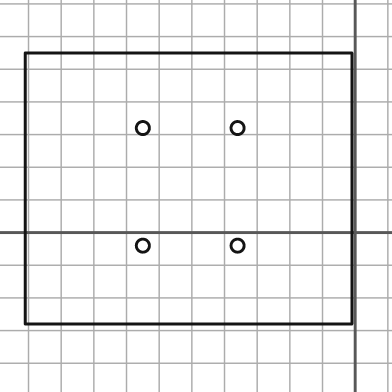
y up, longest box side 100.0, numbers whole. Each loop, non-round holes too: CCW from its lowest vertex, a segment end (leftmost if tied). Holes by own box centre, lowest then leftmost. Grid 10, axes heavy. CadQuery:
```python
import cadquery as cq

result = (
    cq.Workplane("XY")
    .moveTo(-101.0, -28.0)
    .lineTo(-1.0, -28.0)
    .lineTo(-1.0, 55.0)
    .lineTo(-101.0, 55.0)
    .close()
    .moveTo(-65.0, -4.0)
    .circle(2.0)
    .moveTo(-36.0, -4.0)
    .circle(2.0)
    .moveTo(-65.0, 32.0)
    .circle(2.0)
    .moveTo(-36.0, 32.0)
    .circle(2.0)
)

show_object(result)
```